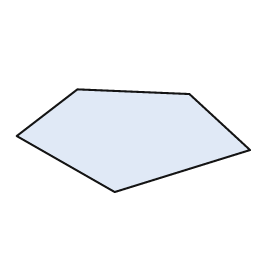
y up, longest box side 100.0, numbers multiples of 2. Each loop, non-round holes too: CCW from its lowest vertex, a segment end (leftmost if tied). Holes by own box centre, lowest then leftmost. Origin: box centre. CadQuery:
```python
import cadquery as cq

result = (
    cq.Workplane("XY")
    .moveTo(-8.0, -22.0)
    .lineTo(50.0, -4.0)
    .lineTo(24.0, 20.0)
    .lineTo(-24.0, 22.0)
    .lineTo(-50.0, 2.0)
    .close()
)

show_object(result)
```